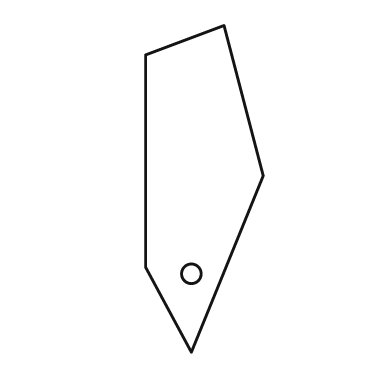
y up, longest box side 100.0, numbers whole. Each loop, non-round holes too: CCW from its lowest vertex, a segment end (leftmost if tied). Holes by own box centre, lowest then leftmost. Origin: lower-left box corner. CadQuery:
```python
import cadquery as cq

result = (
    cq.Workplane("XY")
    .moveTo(14.0, 0.0)
    .lineTo(36.0, 54.0)
    .lineTo(24.0, 100.0)
    .lineTo(0.0, 91.0)
    .lineTo(0.0, 26.0)
    .close()
    .moveTo(14.0, 24.0)
    .circle(3.0)
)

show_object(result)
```